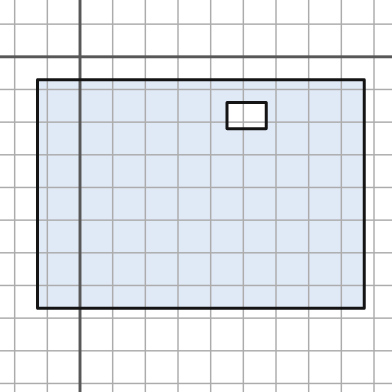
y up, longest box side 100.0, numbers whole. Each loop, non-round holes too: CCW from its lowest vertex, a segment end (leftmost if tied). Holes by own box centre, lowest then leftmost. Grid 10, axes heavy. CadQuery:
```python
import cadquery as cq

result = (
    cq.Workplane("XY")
    .moveTo(-13.0, -77.0)
    .lineTo(87.0, -77.0)
    .lineTo(87.0, -7.0)
    .lineTo(-13.0, -7.0)
    .close()
    .moveTo(45.0, -22.0)
    .lineTo(57.0, -22.0)
    .lineTo(57.0, -14.0)
    .lineTo(45.0, -14.0)
    .close()
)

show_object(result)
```